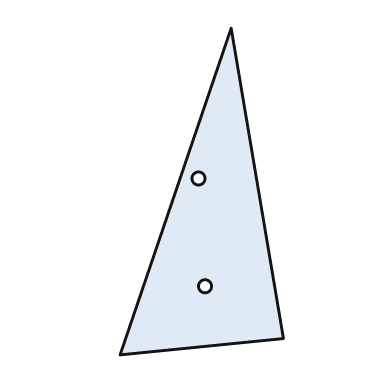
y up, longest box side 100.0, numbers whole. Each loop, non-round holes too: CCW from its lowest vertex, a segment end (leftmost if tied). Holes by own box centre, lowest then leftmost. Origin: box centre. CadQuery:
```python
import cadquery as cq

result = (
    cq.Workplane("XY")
    .moveTo(-25.0, -50.0)
    .lineTo(25.0, -45.0)
    .lineTo(9.0, 50.0)
    .close()
    .moveTo(1.0, -29.0)
    .circle(2.0)
    .moveTo(-1.0, 4.0)
    .circle(2.0)
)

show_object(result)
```